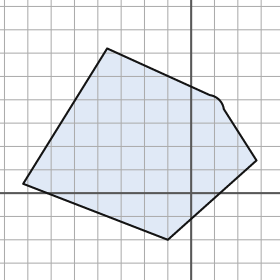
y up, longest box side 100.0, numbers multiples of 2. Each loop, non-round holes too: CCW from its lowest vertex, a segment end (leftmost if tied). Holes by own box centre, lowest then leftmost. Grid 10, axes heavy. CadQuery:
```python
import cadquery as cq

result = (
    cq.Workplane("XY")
    .moveTo(-10.0, -20.0)
    .lineTo(28.0, 14.0)
    .lineTo(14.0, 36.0)
    .threePointArc((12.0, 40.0), (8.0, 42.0))
    .lineTo(-36.0, 62.0)
    .lineTo(-72.0, 4.0)
    .close()
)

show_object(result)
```